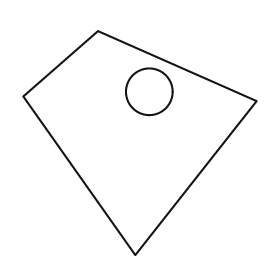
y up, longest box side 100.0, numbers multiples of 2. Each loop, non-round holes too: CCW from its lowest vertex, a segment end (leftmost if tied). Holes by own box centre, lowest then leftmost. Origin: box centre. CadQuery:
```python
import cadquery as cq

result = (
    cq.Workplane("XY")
    .moveTo(-2.0, -48.0)
    .lineTo(50.0, 18.0)
    .lineTo(-18.0, 48.0)
    .lineTo(-50.0, 20.0)
    .close()
    .moveTo(4.0, 22.0)
    .circle(10.0)
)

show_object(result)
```